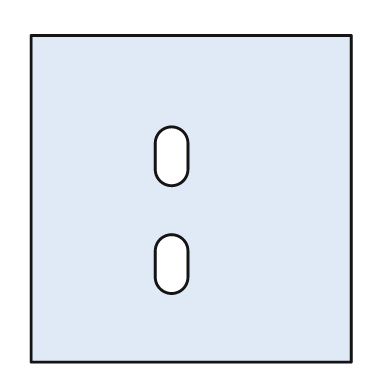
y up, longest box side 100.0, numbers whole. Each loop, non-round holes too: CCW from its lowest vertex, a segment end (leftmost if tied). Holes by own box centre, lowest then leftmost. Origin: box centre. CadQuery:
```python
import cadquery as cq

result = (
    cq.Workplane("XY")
    .moveTo(-49.0, -50.0)
    .lineTo(49.0, -50.0)
    .lineTo(49.0, 50.0)
    .lineTo(-49.0, 50.0)
    .close()
    .moveTo(-11.0, -24.0)
    .threePointArc((-6.0, -29.0), (-1.0, -24.0))
    .lineTo(-1.0, -16.0)
    .threePointArc((-6.0, -11.0), (-11.0, -16.0))
    .close()
    .moveTo(-11.0, 9.0)
    .threePointArc((-6.0, 4.0), (-1.0, 9.0))
    .lineTo(-1.0, 17.0)
    .threePointArc((-6.0, 22.0), (-11.0, 17.0))
    .close()
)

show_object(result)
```